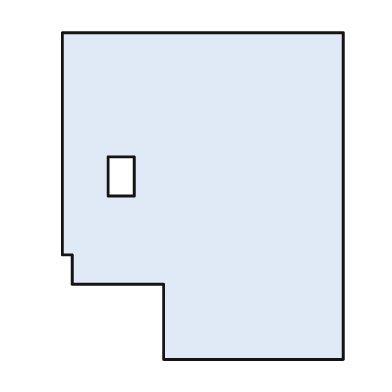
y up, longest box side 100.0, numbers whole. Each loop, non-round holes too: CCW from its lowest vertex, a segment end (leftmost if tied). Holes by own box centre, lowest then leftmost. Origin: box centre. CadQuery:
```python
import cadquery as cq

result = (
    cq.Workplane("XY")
    .moveTo(-12.0, -50.0)
    .lineTo(43.0, -50.0)
    .lineTo(43.0, 50.0)
    .lineTo(-43.0, 50.0)
    .lineTo(-43.0, -18.0)
    .lineTo(-40.0, -18.0)
    .lineTo(-40.0, -27.0)
    .lineTo(-12.0, -27.0)
    .close()
    .moveTo(-29.0, 0.0)
    .lineTo(-21.0, 0.0)
    .lineTo(-21.0, 12.0)
    .lineTo(-29.0, 12.0)
    .close()
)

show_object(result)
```